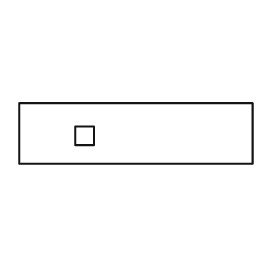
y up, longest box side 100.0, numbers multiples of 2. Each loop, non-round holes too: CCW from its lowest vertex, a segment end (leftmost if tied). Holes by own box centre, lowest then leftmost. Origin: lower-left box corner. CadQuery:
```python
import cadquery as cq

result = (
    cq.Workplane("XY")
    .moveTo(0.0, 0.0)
    .lineTo(100.0, 0.0)
    .lineTo(100.0, 26.0)
    .lineTo(0.0, 26.0)
    .close()
    .moveTo(24.0, 8.0)
    .lineTo(32.0, 8.0)
    .lineTo(32.0, 16.0)
    .lineTo(24.0, 16.0)
    .close()
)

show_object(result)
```